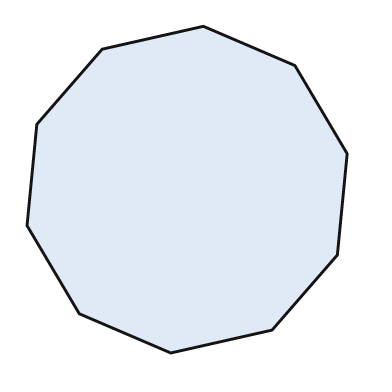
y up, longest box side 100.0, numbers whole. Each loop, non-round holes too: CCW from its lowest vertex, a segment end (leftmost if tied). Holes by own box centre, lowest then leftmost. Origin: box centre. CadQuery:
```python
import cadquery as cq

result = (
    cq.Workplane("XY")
    .moveTo(-5.0, -50.0)
    .lineTo(26.0, -43.0)
    .lineTo(46.0, -20.0)
    .lineTo(49.0, 11.0)
    .lineTo(33.0, 38.0)
    .lineTo(5.0, 50.0)
    .lineTo(-26.0, 43.0)
    .lineTo(-46.0, 20.0)
    .lineTo(-49.0, -11.0)
    .lineTo(-33.0, -38.0)
    .close()
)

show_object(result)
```